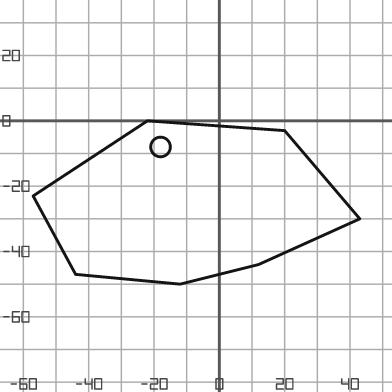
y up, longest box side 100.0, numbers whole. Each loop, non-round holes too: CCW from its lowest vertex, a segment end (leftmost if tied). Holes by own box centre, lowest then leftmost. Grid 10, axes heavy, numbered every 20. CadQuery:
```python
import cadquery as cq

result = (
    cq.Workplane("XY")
    .moveTo(-12.0, -50.0)
    .lineTo(12.0, -44.0)
    .lineTo(43.0, -30.0)
    .lineTo(20.0, -3.0)
    .lineTo(-22.0, 0.0)
    .lineTo(-57.0, -23.0)
    .lineTo(-44.0, -47.0)
    .close()
    .moveTo(-18.0, -8.0)
    .circle(3.0)
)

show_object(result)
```